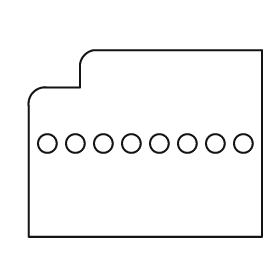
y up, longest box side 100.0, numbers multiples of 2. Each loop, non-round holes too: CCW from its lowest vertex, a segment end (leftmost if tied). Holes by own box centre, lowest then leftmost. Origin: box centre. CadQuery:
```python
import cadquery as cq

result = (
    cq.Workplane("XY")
    .moveTo(-50.0, -40.0)
    .lineTo(50.0, -40.0)
    .lineTo(50.0, 40.0)
    .lineTo(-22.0, 40.0)
    .threePointArc((-26.0, 38.0), (-28.0, 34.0))
    .lineTo(-28.0, 24.0)
    .lineTo(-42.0, 24.0)
    .threePointArc((-48.0, 22.0), (-50.0, 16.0))
    .close()
    .moveTo(-42.0, 0.0)
    .circle(4.0)
    .moveTo(-30.0, 0.0)
    .circle(4.0)
    .moveTo(-18.0, 0.0)
    .circle(4.0)
    .moveTo(-6.0, 0.0)
    .circle(4.0)
    .moveTo(6.0, 0.0)
    .circle(4.0)
    .moveTo(18.0, 0.0)
    .circle(4.0)
    .moveTo(30.0, 0.0)
    .circle(4.0)
    .moveTo(42.0, 0.0)
    .circle(4.0)
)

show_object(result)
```